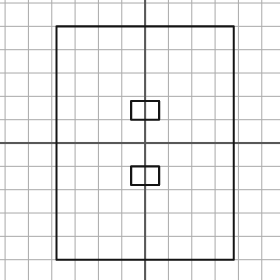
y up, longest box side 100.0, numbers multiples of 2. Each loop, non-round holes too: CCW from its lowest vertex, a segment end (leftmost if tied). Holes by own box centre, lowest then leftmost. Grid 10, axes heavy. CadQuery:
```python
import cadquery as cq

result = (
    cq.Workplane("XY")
    .moveTo(-38.0, -50.0)
    .lineTo(38.0, -50.0)
    .lineTo(38.0, 50.0)
    .lineTo(-38.0, 50.0)
    .close()
    .moveTo(-6.0, -18.0)
    .lineTo(6.0, -18.0)
    .lineTo(6.0, -10.0)
    .lineTo(-6.0, -10.0)
    .close()
    .moveTo(-6.0, 10.0)
    .lineTo(6.0, 10.0)
    .lineTo(6.0, 18.0)
    .lineTo(-6.0, 18.0)
    .close()
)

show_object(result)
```